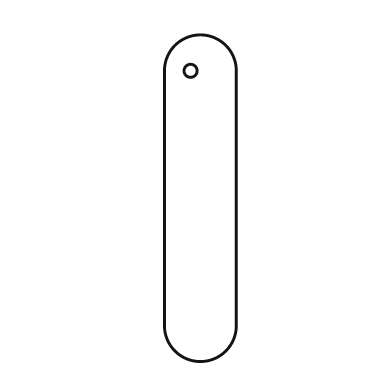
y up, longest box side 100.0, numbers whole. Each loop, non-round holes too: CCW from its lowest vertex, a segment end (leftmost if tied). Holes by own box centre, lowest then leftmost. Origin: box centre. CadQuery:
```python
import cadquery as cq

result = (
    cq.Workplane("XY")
    .moveTo(-11.0, -39.0)
    .threePointArc((0.0, -50.0), (11.0, -39.0))
    .lineTo(11.0, 39.0)
    .threePointArc((0.0, 50.0), (-11.0, 39.0))
    .close()
    .moveTo(-3.0, 39.0)
    .circle(2.0)
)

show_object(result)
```